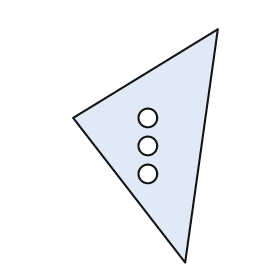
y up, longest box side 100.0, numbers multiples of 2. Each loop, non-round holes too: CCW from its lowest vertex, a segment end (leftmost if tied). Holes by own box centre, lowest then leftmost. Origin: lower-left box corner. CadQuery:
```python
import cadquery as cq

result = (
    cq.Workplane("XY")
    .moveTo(48.0, 0.0)
    .lineTo(62.0, 100.0)
    .lineTo(0.0, 62.0)
    .close()
    .moveTo(32.0, 38.0)
    .circle(4.0)
    .moveTo(32.0, 50.0)
    .circle(4.0)
    .moveTo(32.0, 62.0)
    .circle(4.0)
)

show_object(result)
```